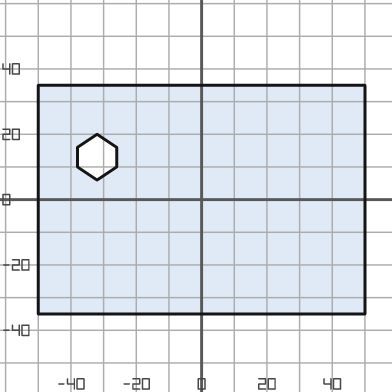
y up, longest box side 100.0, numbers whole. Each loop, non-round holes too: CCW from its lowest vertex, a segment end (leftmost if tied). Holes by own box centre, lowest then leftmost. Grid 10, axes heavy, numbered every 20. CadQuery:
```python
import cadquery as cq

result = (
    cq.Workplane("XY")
    .moveTo(-50.0, -35.0)
    .lineTo(50.0, -35.0)
    .lineTo(50.0, 35.0)
    .lineTo(-50.0, 35.0)
    .close()
    .moveTo(-32.0, 6.0)
    .lineTo(-26.0, 10.0)
    .lineTo(-26.0, 16.0)
    .lineTo(-32.0, 20.0)
    .lineTo(-38.0, 16.0)
    .lineTo(-38.0, 10.0)
    .close()
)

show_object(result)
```